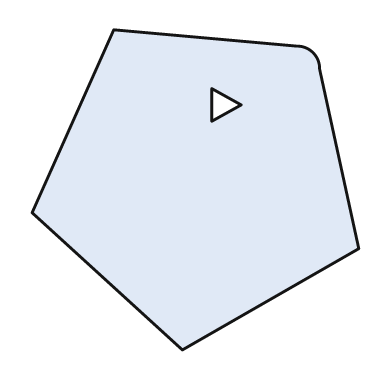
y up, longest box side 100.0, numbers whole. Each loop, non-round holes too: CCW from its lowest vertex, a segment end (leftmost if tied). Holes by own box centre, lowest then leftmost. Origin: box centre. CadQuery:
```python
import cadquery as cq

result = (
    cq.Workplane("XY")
    .moveTo(-4.0, -49.0)
    .lineTo(50.0, -18.0)
    .lineTo(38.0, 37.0)
    .threePointArc((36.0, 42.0), (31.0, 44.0))
    .lineTo(-25.0, 49.0)
    .lineTo(-50.0, -7.0)
    .close()
    .moveTo(5.0, 21.0)
    .lineTo(14.0, 26.0)
    .lineTo(5.0, 31.0)
    .close()
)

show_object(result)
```